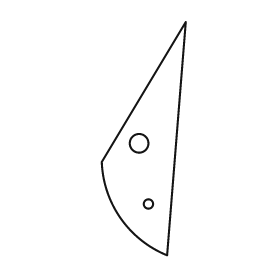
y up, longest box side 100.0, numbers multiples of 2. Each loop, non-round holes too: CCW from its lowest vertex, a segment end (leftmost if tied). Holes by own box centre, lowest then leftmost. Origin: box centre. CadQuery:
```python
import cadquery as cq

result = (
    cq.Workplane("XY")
    .moveTo(10.0, -50.0)
    .lineTo(18.0, 50.0)
    .lineTo(-18.0, -10.0)
    .threePointArc((-10.0, -34.0), (10.0, -50.0))
    .close()
    .moveTo(2.0, -28.0)
    .circle(2.0)
    .moveTo(-2.0, -2.0)
    .circle(4.0)
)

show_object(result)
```